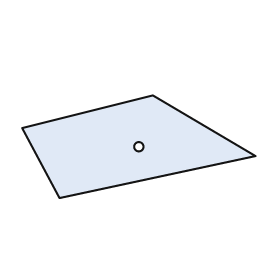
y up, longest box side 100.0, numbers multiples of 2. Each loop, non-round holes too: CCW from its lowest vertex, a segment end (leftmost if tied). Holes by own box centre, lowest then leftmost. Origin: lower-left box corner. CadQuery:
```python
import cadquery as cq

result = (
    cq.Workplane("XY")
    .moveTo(16.0, 0.0)
    .lineTo(100.0, 18.0)
    .lineTo(56.0, 44.0)
    .lineTo(0.0, 30.0)
    .close()
    .moveTo(50.0, 22.0)
    .circle(2.0)
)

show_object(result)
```